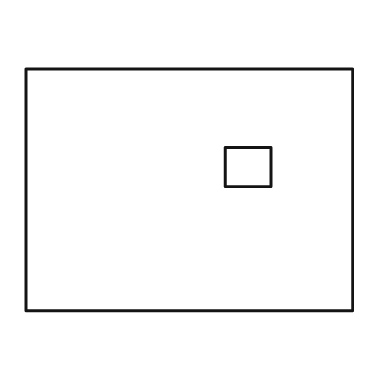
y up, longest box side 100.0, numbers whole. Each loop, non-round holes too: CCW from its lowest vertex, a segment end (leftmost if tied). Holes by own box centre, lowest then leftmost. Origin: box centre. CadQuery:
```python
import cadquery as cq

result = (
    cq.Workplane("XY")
    .moveTo(-50.0, -37.0)
    .lineTo(50.0, -37.0)
    .lineTo(50.0, 37.0)
    .lineTo(-50.0, 37.0)
    .close()
    .moveTo(11.0, 1.0)
    .lineTo(25.0, 1.0)
    .lineTo(25.0, 13.0)
    .lineTo(11.0, 13.0)
    .close()
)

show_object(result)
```